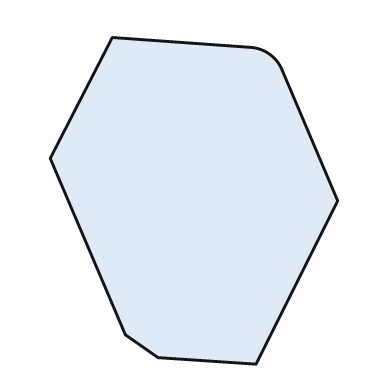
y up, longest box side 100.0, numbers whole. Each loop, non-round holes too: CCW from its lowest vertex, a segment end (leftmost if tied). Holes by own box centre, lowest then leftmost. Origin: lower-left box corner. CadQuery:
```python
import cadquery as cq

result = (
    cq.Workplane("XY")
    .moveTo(63.0, 0.0)
    .lineTo(88.0, 50.0)
    .lineTo(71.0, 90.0)
    .threePointArc((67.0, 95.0), (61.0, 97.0))
    .lineTo(19.0, 100.0)
    .lineTo(0.0, 63.0)
    .lineTo(23.0, 9.0)
    .lineTo(33.0, 2.0)
    .close()
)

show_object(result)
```